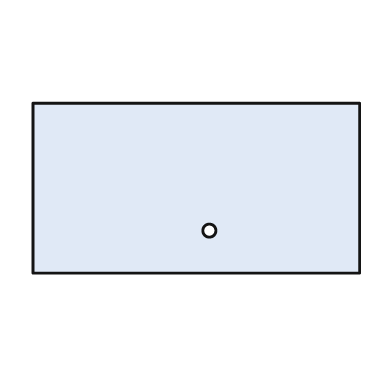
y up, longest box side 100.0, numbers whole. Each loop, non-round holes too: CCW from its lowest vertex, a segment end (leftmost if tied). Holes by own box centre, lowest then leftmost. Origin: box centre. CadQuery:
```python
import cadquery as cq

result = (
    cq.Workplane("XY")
    .moveTo(-50.0, -26.0)
    .lineTo(50.0, -26.0)
    .lineTo(50.0, 26.0)
    .lineTo(-50.0, 26.0)
    .close()
    .moveTo(4.0, -13.0)
    .circle(2.0)
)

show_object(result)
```